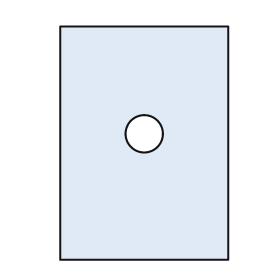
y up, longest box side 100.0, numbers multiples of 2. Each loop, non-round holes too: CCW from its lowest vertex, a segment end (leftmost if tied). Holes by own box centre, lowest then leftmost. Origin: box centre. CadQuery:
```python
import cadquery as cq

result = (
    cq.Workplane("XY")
    .moveTo(-36.0, -50.0)
    .lineTo(36.0, -50.0)
    .lineTo(36.0, 50.0)
    .lineTo(-36.0, 50.0)
    .close()
    .moveTo(0.0, 4.0)
    .circle(8.0)
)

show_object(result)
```